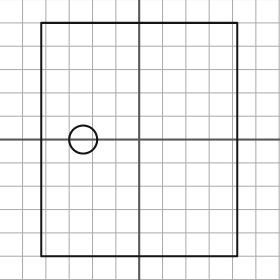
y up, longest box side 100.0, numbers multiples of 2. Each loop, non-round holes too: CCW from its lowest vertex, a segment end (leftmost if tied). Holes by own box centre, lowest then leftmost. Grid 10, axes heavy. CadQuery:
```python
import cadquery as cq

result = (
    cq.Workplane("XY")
    .moveTo(-42.0, -50.0)
    .lineTo(42.0, -50.0)
    .lineTo(42.0, 50.0)
    .lineTo(-42.0, 50.0)
    .close()
    .moveTo(-24.0, 0.0)
    .circle(6.0)
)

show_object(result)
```